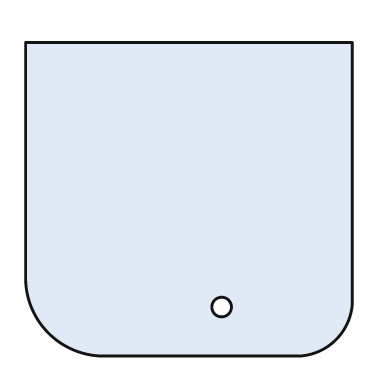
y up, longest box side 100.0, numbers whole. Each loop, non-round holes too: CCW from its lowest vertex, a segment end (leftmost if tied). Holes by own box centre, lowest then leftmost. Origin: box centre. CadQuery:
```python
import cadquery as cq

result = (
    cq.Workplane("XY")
    .moveTo(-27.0, -48.0)
    .lineTo(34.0, -48.0)
    .threePointArc((45.0, -43.0), (50.0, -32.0))
    .lineTo(50.0, 48.0)
    .lineTo(-50.0, 48.0)
    .lineTo(-50.0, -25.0)
    .threePointArc((-43.0, -41.0), (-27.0, -48.0))
    .close()
    .moveTo(10.0, -33.0)
    .circle(3.0)
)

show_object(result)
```